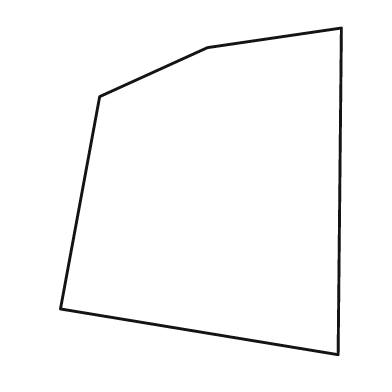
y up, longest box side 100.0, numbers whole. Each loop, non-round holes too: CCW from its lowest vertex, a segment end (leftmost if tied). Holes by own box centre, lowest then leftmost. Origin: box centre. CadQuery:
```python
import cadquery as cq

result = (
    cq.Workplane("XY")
    .moveTo(42.0, -50.0)
    .lineTo(43.0, 50.0)
    .lineTo(2.0, 44.0)
    .lineTo(-31.0, 29.0)
    .lineTo(-43.0, -36.0)
    .close()
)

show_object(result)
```